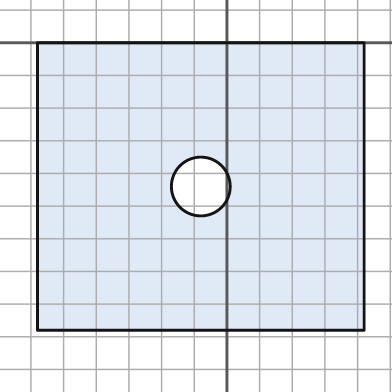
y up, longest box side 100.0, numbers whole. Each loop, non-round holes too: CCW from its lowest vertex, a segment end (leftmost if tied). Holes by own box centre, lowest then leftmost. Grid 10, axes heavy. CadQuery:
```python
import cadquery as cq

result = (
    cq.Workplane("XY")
    .moveTo(-58.0, -88.0)
    .lineTo(42.0, -88.0)
    .lineTo(42.0, 0.0)
    .lineTo(-58.0, 0.0)
    .close()
    .moveTo(-8.0, -44.0)
    .circle(9.0)
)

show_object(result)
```